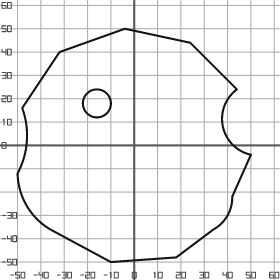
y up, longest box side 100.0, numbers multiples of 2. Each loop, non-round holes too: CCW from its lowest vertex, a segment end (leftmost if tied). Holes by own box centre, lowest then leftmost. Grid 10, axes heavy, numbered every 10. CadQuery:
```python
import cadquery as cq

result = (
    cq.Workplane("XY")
    .moveTo(-10.0, -50.0)
    .lineTo(18.0, -48.0)
    .lineTo(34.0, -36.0)
    .threePointArc((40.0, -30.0), (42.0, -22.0))
    .lineTo(50.0, -4.0)
    .threePointArc((38.0, 8.0), (44.0, 24.0))
    .lineTo(24.0, 44.0)
    .lineTo(-4.0, 50.0)
    .lineTo(-32.0, 40.0)
    .lineTo(-48.0, 16.0)
    .threePointArc((-46.0, 2.0), (-50.0, -12.0))
    .threePointArc((-46.0, -26.0), (-36.0, -36.0))
    .close()
    .moveTo(-16.0, 18.0)
    .circle(6.0)
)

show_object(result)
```